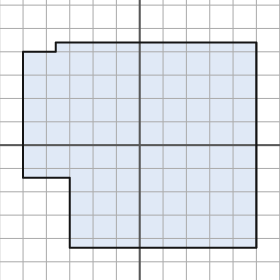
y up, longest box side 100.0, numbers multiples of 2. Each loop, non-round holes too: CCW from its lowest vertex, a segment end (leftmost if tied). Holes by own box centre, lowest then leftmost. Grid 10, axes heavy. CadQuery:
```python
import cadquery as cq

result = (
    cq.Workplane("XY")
    .moveTo(-30.0, -44.0)
    .lineTo(50.0, -44.0)
    .lineTo(50.0, 44.0)
    .lineTo(-36.0, 44.0)
    .lineTo(-36.0, 40.0)
    .lineTo(-50.0, 40.0)
    .lineTo(-50.0, -14.0)
    .lineTo(-30.0, -14.0)
    .close()
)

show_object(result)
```